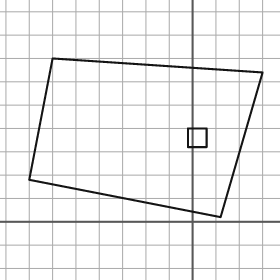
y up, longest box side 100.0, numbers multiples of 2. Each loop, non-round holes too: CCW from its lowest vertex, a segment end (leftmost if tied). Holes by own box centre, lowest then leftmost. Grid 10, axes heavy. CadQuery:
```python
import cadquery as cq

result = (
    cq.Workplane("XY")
    .moveTo(12.0, 2.0)
    .lineTo(30.0, 64.0)
    .lineTo(-60.0, 70.0)
    .lineTo(-70.0, 18.0)
    .close()
    .moveTo(-2.0, 32.0)
    .lineTo(6.0, 32.0)
    .lineTo(6.0, 40.0)
    .lineTo(-2.0, 40.0)
    .close()
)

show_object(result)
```